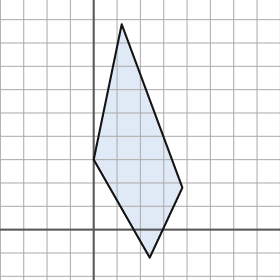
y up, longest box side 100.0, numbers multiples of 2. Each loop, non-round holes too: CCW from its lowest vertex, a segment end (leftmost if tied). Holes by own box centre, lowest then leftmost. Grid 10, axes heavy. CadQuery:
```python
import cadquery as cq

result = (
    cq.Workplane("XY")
    .moveTo(24.0, -12.0)
    .lineTo(38.0, 18.0)
    .lineTo(12.0, 88.0)
    .lineTo(0.0, 30.0)
    .close()
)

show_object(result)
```